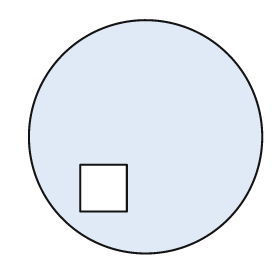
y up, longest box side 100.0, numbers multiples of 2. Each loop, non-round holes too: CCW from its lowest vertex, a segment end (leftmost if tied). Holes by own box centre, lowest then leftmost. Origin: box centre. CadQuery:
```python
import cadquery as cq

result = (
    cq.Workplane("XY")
    .moveTo(0.0, 0.0)
    .circle(50.0)
    .moveTo(-28.0, -32.0)
    .lineTo(-8.0, -32.0)
    .lineTo(-8.0, -12.0)
    .lineTo(-28.0, -12.0)
    .close()
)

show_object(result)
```